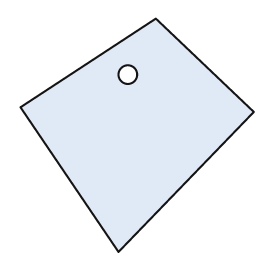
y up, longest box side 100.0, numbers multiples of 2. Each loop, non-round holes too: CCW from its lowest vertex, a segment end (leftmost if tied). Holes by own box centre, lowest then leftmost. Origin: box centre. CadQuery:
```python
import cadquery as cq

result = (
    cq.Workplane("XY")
    .moveTo(-8.0, -50.0)
    .lineTo(50.0, 10.0)
    .lineTo(8.0, 50.0)
    .lineTo(-50.0, 12.0)
    .close()
    .moveTo(-4.0, 26.0)
    .circle(4.0)
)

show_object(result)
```